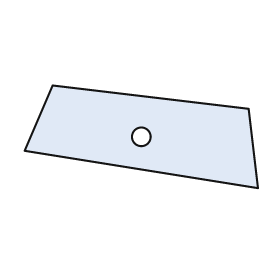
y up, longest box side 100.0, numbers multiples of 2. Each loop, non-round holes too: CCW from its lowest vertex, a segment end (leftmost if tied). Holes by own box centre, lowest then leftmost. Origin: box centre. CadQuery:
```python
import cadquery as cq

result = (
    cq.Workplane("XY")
    .moveTo(50.0, -22.0)
    .lineTo(46.0, 12.0)
    .lineTo(-38.0, 22.0)
    .lineTo(-50.0, -6.0)
    .close()
    .moveTo(0.0, 0.0)
    .circle(4.0)
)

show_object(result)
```